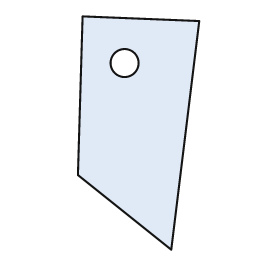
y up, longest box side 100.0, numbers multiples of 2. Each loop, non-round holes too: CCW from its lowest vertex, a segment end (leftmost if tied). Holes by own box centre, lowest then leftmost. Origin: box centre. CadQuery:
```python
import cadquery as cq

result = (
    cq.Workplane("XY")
    .moveTo(14.0, -50.0)
    .lineTo(26.0, 48.0)
    .lineTo(-24.0, 50.0)
    .lineTo(-26.0, -18.0)
    .close()
    .moveTo(-6.0, 30.0)
    .circle(6.0)
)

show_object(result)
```